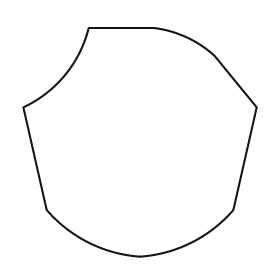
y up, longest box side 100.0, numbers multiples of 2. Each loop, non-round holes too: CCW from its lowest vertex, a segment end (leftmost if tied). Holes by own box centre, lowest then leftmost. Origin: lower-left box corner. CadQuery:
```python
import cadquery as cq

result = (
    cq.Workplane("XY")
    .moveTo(50.0, 0.0)
    .threePointArc((72.0, 6.0), (90.0, 20.0))
    .lineTo(100.0, 64.0)
    .lineTo(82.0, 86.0)
    .threePointArc((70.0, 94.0), (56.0, 98.0))
    .lineTo(28.0, 98.0)
    .threePointArc((18.0, 78.0), (0.0, 64.0))
    .lineTo(10.0, 20.0)
    .threePointArc((28.0, 6.0), (50.0, 0.0))
    .close()
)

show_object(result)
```